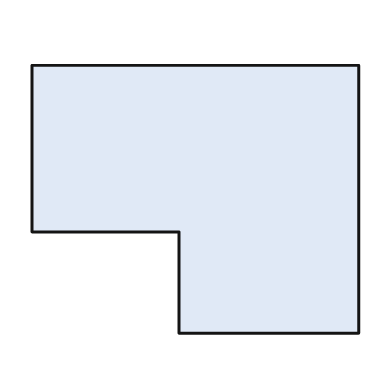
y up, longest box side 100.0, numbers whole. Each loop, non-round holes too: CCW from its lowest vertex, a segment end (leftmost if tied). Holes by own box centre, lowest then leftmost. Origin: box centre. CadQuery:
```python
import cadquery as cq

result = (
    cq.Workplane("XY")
    .moveTo(-5.0, -41.0)
    .lineTo(50.0, -41.0)
    .lineTo(50.0, 41.0)
    .lineTo(-50.0, 41.0)
    .lineTo(-50.0, -10.0)
    .lineTo(-5.0, -10.0)
    .close()
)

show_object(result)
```